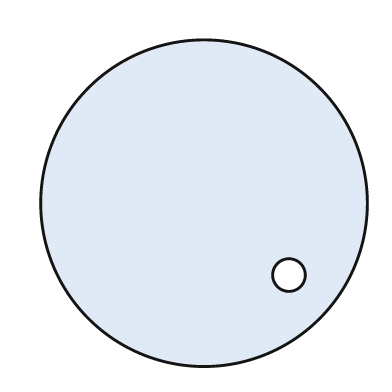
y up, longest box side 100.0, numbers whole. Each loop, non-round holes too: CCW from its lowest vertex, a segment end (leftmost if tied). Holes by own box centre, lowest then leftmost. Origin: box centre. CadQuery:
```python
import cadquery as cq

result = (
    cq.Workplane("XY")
    .moveTo(0.0, 0.0)
    .circle(50.0)
    .moveTo(26.0, -22.0)
    .circle(5.0)
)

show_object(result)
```